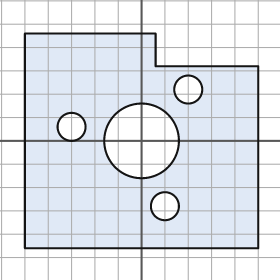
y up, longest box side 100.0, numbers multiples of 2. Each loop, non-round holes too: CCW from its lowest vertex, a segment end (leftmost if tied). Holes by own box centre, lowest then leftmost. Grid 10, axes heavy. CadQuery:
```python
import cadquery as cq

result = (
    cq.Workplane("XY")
    .moveTo(-50.0, -46.0)
    .lineTo(50.0, -46.0)
    .lineTo(50.0, 32.0)
    .lineTo(6.0, 32.0)
    .lineTo(6.0, 46.0)
    .lineTo(-50.0, 46.0)
    .close()
    .moveTo(10.0, -28.0)
    .circle(6.0)
    .moveTo(0.0, 0.0)
    .circle(16.0)
    .moveTo(-30.0, 6.0)
    .circle(6.0)
    .moveTo(20.0, 22.0)
    .circle(6.0)
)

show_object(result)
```